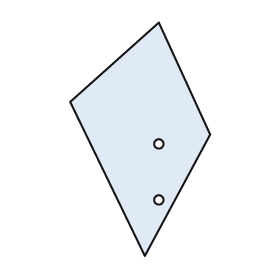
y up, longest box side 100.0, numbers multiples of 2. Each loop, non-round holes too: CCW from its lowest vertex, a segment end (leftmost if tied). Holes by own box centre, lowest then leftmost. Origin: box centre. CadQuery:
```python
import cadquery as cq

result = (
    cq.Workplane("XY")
    .moveTo(2.0, -50.0)
    .lineTo(30.0, 2.0)
    .lineTo(8.0, 50.0)
    .lineTo(-30.0, 16.0)
    .close()
    .moveTo(8.0, -26.0)
    .circle(2.0)
    .moveTo(8.0, -2.0)
    .circle(2.0)
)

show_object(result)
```